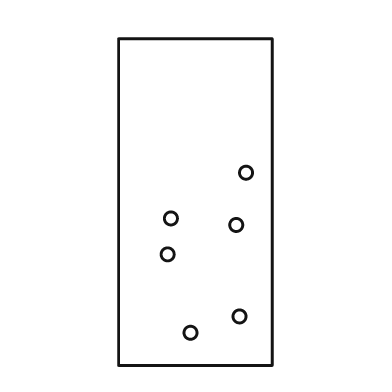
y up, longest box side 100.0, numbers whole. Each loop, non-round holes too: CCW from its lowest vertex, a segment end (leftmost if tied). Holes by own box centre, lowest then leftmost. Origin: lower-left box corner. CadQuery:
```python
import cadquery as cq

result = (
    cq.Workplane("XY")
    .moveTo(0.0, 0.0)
    .lineTo(47.0, 0.0)
    .lineTo(47.0, 100.0)
    .lineTo(0.0, 100.0)
    .close()
    .moveTo(22.0, 10.0)
    .circle(2.0)
    .moveTo(37.0, 15.0)
    .circle(2.0)
    .moveTo(15.0, 34.0)
    .circle(2.0)
    .moveTo(36.0, 43.0)
    .circle(2.0)
    .moveTo(16.0, 45.0)
    .circle(2.0)
    .moveTo(39.0, 59.0)
    .circle(2.0)
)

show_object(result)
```